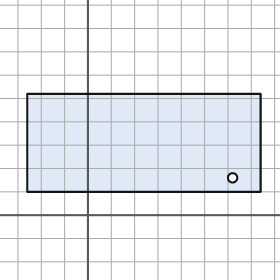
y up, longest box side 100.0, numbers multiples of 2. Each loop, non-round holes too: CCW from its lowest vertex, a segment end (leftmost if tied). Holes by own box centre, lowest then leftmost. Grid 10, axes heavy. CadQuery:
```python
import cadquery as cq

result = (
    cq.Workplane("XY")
    .moveTo(-26.0, 10.0)
    .lineTo(74.0, 10.0)
    .lineTo(74.0, 52.0)
    .lineTo(-26.0, 52.0)
    .close()
    .moveTo(62.0, 16.0)
    .circle(2.0)
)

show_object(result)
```